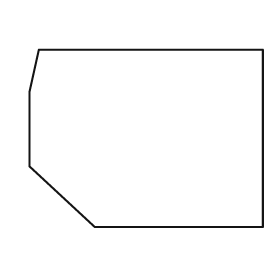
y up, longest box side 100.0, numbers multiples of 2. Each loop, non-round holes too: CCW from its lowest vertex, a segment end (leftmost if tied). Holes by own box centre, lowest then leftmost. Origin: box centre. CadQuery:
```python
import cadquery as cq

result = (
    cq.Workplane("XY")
    .moveTo(-22.0, -38.0)
    .lineTo(50.0, -38.0)
    .lineTo(50.0, 38.0)
    .lineTo(-46.0, 38.0)
    .lineTo(-50.0, 20.0)
    .lineTo(-50.0, -12.0)
    .close()
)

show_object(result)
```